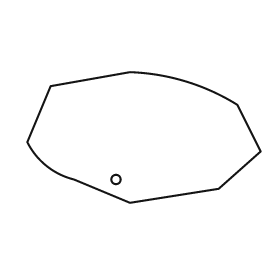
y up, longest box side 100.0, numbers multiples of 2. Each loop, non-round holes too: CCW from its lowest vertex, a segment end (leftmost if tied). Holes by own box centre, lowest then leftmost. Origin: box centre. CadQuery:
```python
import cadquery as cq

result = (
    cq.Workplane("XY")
    .moveTo(-6.0, -28.0)
    .lineTo(32.0, -22.0)
    .lineTo(50.0, -6.0)
    .lineTo(40.0, 14.0)
    .threePointArc((18.0, 24.0), (-6.0, 28.0))
    .lineTo(-40.0, 22.0)
    .lineTo(-50.0, -2.0)
    .threePointArc((-42.0, -12.0), (-30.0, -18.0))
    .close()
    .moveTo(-12.0, -18.0)
    .circle(2.0)
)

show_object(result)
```